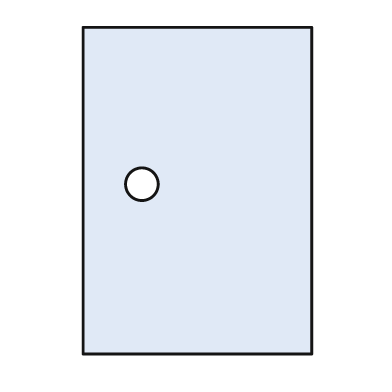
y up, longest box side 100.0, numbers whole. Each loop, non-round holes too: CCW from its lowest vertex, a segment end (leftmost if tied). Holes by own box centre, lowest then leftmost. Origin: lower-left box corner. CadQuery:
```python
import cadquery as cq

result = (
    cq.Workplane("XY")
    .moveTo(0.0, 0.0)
    .lineTo(70.0, 0.0)
    .lineTo(70.0, 100.0)
    .lineTo(0.0, 100.0)
    .close()
    .moveTo(18.0, 52.0)
    .circle(5.0)
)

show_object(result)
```